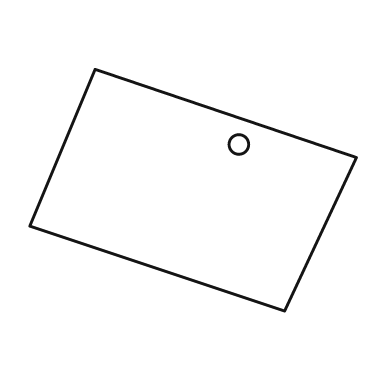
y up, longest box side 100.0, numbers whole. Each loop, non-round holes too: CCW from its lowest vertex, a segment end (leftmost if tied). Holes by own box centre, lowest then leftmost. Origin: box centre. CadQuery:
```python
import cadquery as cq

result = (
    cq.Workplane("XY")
    .moveTo(28.0, -37.0)
    .lineTo(50.0, 10.0)
    .lineTo(-30.0, 37.0)
    .lineTo(-50.0, -11.0)
    .close()
    .moveTo(14.0, 14.0)
    .circle(3.0)
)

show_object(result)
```